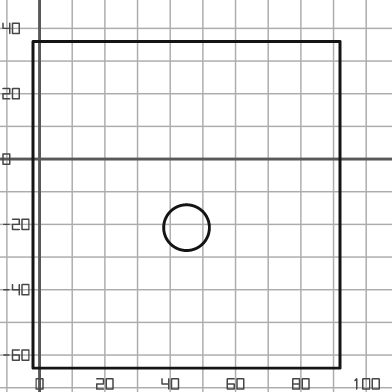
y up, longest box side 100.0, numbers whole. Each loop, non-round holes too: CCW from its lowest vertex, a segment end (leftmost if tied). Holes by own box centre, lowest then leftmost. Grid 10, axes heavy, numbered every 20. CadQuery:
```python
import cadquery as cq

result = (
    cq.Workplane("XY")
    .moveTo(-2.0, -64.0)
    .lineTo(92.0, -64.0)
    .lineTo(92.0, 36.0)
    .lineTo(-2.0, 36.0)
    .close()
    .moveTo(45.0, -21.0)
    .circle(7.0)
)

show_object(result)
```